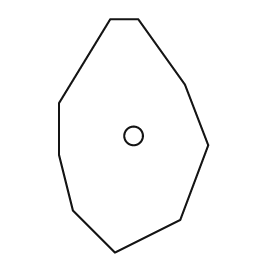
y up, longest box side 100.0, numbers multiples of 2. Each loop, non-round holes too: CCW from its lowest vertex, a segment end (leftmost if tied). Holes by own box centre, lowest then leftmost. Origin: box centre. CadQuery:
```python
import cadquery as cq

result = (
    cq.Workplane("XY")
    .moveTo(-8.0, -50.0)
    .lineTo(20.0, -36.0)
    .lineTo(32.0, -4.0)
    .lineTo(22.0, 22.0)
    .lineTo(2.0, 50.0)
    .lineTo(-10.0, 50.0)
    .lineTo(-32.0, 14.0)
    .lineTo(-32.0, -8.0)
    .lineTo(-26.0, -32.0)
    .close()
    .moveTo(0.0, 0.0)
    .circle(4.0)
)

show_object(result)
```